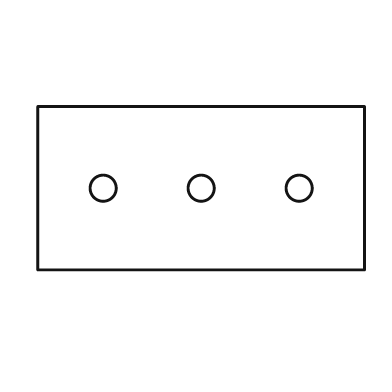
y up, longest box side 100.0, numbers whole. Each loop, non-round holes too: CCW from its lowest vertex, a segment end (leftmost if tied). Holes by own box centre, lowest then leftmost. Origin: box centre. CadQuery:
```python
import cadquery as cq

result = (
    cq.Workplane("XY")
    .moveTo(-50.0, -25.0)
    .lineTo(50.0, -25.0)
    .lineTo(50.0, 25.0)
    .lineTo(-50.0, 25.0)
    .close()
    .moveTo(-30.0, 0.0)
    .circle(4.0)
    .moveTo(0.0, 0.0)
    .circle(4.0)
    .moveTo(30.0, 0.0)
    .circle(4.0)
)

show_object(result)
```